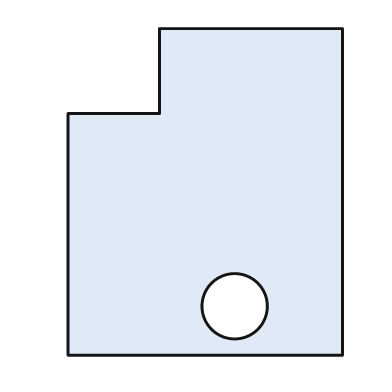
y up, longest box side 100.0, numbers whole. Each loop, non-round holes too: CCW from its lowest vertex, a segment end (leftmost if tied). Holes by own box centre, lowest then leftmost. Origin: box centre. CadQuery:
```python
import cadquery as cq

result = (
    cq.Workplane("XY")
    .moveTo(-42.0, -50.0)
    .lineTo(42.0, -50.0)
    .lineTo(42.0, 50.0)
    .lineTo(-14.0, 50.0)
    .lineTo(-14.0, 24.0)
    .lineTo(-42.0, 24.0)
    .close()
    .moveTo(9.0, -35.0)
    .circle(10.0)
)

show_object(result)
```